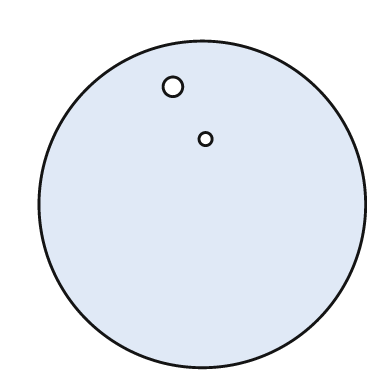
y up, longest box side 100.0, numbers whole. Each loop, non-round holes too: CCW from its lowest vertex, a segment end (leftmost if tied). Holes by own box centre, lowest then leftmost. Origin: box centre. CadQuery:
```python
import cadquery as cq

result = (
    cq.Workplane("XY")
    .moveTo(0.0, 0.0)
    .circle(50.0)
    .moveTo(1.0, 20.0)
    .circle(2.0)
    .moveTo(-9.0, 36.0)
    .circle(3.0)
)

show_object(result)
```